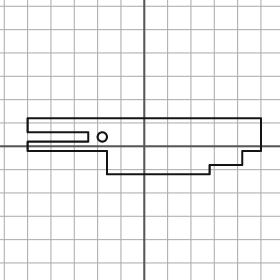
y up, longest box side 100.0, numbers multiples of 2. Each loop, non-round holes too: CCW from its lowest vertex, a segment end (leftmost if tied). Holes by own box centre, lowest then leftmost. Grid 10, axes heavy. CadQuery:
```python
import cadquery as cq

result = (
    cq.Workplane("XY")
    .moveTo(-16.0, -12.0)
    .lineTo(28.0, -12.0)
    .lineTo(28.0, -8.0)
    .lineTo(42.0, -8.0)
    .lineTo(42.0, -2.0)
    .lineTo(50.0, -2.0)
    .lineTo(50.0, 12.0)
    .lineTo(-50.0, 12.0)
    .lineTo(-50.0, 6.0)
    .lineTo(-24.0, 6.0)
    .lineTo(-24.0, 2.0)
    .lineTo(-50.0, 2.0)
    .lineTo(-50.0, -2.0)
    .lineTo(-16.0, -2.0)
    .close()
    .moveTo(-18.0, 4.0)
    .circle(2.0)
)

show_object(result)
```